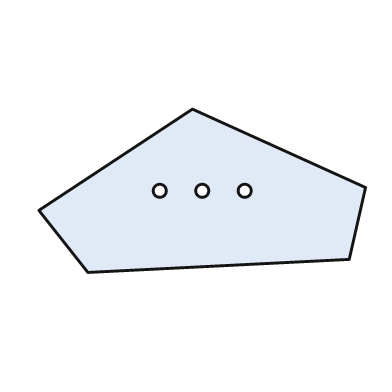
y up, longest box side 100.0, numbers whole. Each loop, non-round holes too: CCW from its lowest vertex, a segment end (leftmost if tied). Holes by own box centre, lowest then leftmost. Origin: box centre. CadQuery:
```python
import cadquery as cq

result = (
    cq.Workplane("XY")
    .moveTo(-35.0, -25.0)
    .lineTo(45.0, -21.0)
    .lineTo(50.0, 1.0)
    .lineTo(-3.0, 25.0)
    .lineTo(-50.0, -6.0)
    .close()
    .moveTo(-13.0, 0.0)
    .circle(2.0)
    .moveTo(0.0, 0.0)
    .circle(2.0)
    .moveTo(13.0, 0.0)
    .circle(2.0)
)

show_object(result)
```